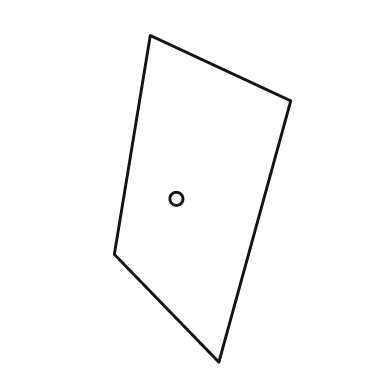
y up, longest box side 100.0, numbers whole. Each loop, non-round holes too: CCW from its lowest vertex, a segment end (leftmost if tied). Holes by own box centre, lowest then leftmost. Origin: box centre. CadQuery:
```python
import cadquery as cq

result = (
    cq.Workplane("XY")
    .moveTo(5.0, -50.0)
    .lineTo(27.0, 30.0)
    .lineTo(-16.0, 50.0)
    .lineTo(-27.0, -17.0)
    .close()
    .moveTo(-8.0, 0.0)
    .circle(2.0)
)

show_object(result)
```